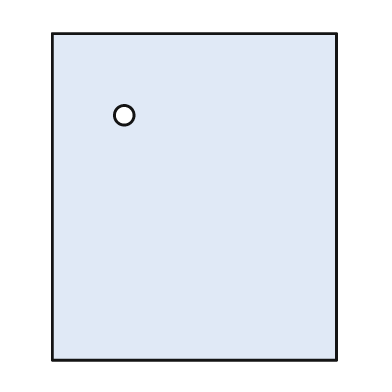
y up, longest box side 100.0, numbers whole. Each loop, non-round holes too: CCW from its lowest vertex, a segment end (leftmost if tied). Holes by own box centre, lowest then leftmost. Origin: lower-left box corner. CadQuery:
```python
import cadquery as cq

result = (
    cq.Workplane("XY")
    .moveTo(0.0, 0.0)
    .lineTo(87.0, 0.0)
    .lineTo(87.0, 100.0)
    .lineTo(0.0, 100.0)
    .close()
    .moveTo(22.0, 75.0)
    .circle(3.0)
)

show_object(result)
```